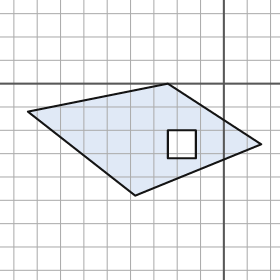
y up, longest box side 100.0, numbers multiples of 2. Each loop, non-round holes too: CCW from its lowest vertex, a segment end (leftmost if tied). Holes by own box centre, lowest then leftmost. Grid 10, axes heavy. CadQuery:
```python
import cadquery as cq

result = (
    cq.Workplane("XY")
    .moveTo(-38.0, -48.0)
    .lineTo(16.0, -26.0)
    .lineTo(-24.0, 0.0)
    .lineTo(-84.0, -12.0)
    .close()
    .moveTo(-24.0, -32.0)
    .lineTo(-12.0, -32.0)
    .lineTo(-12.0, -20.0)
    .lineTo(-24.0, -20.0)
    .close()
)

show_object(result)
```